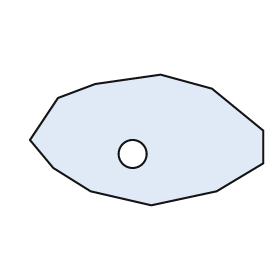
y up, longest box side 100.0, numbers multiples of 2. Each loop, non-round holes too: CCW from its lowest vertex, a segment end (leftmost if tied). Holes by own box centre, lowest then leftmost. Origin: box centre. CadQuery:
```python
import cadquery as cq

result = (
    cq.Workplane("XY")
    .moveTo(2.0, -28.0)
    .lineTo(30.0, -22.0)
    .lineTo(50.0, -10.0)
    .lineTo(50.0, 4.0)
    .lineTo(28.0, 22.0)
    .lineTo(6.0, 28.0)
    .lineTo(-22.0, 24.0)
    .lineTo(-38.0, 18.0)
    .lineTo(-50.0, 0.0)
    .lineTo(-40.0, -12.0)
    .lineTo(-24.0, -22.0)
    .close()
    .moveTo(-6.0, -6.0)
    .circle(6.0)
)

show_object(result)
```